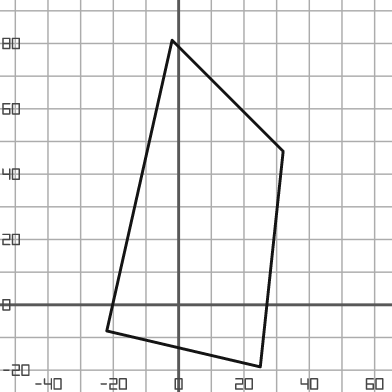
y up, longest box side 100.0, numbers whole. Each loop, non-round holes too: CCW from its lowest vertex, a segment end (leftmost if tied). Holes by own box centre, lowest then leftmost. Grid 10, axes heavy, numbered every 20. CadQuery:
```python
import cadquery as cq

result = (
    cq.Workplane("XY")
    .moveTo(25.0, -19.0)
    .lineTo(32.0, 47.0)
    .lineTo(-2.0, 81.0)
    .lineTo(-22.0, -8.0)
    .close()
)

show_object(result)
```